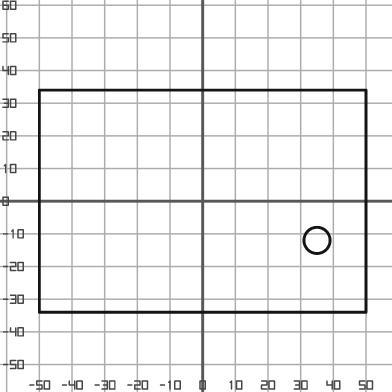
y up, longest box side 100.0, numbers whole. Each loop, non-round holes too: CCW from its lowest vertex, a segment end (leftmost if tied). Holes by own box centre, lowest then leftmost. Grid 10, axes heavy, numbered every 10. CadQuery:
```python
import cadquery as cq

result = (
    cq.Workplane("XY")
    .moveTo(-50.0, -34.0)
    .lineTo(50.0, -34.0)
    .lineTo(50.0, 34.0)
    .lineTo(-50.0, 34.0)
    .close()
    .moveTo(35.0, -12.0)
    .circle(4.0)
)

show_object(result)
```